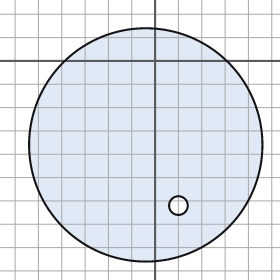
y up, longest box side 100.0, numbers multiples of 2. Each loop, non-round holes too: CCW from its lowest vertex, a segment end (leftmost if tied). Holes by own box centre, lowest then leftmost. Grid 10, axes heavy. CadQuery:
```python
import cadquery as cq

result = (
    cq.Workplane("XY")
    .moveTo(-4.0, -36.0)
    .circle(50.0)
    .moveTo(10.0, -62.0)
    .circle(4.0)
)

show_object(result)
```